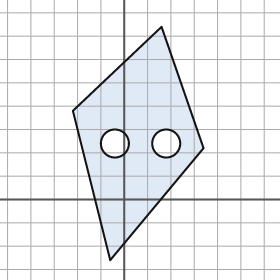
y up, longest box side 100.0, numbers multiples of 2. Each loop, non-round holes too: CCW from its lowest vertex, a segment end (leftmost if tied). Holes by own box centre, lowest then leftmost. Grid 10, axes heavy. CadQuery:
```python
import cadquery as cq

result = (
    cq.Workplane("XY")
    .moveTo(-6.0, -26.0)
    .lineTo(34.0, 22.0)
    .lineTo(16.0, 74.0)
    .lineTo(-22.0, 38.0)
    .close()
    .moveTo(-4.0, 24.0)
    .circle(6.0)
    .moveTo(18.0, 24.0)
    .circle(6.0)
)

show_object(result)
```